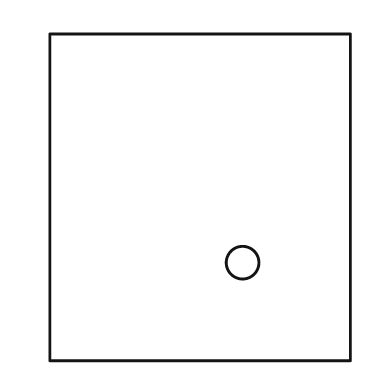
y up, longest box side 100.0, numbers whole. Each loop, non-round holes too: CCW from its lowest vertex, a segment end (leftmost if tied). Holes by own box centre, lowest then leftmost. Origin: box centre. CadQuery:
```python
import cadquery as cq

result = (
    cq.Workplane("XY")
    .moveTo(-46.0, -50.0)
    .lineTo(46.0, -50.0)
    .lineTo(46.0, 50.0)
    .lineTo(-46.0, 50.0)
    .close()
    .moveTo(13.0, -20.0)
    .circle(5.0)
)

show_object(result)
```